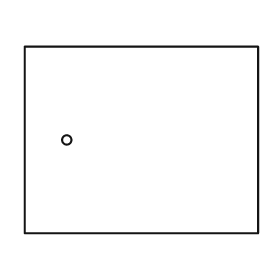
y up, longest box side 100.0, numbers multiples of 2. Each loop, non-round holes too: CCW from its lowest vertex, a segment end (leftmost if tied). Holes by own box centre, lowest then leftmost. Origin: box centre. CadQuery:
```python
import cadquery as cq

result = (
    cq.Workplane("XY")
    .moveTo(-50.0, -40.0)
    .lineTo(50.0, -40.0)
    .lineTo(50.0, 40.0)
    .lineTo(-50.0, 40.0)
    .close()
    .moveTo(-32.0, 0.0)
    .circle(2.0)
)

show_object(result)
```